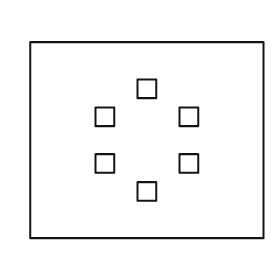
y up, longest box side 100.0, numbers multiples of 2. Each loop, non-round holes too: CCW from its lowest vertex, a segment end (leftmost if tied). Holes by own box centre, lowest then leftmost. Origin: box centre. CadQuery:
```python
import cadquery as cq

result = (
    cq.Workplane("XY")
    .moveTo(-50.0, -42.0)
    .lineTo(50.0, -42.0)
    .lineTo(50.0, 42.0)
    .lineTo(-50.0, 42.0)
    .close()
    .moveTo(-4.0, -26.0)
    .lineTo(4.0, -26.0)
    .lineTo(4.0, -18.0)
    .lineTo(-4.0, -18.0)
    .close()
    .moveTo(-22.0, -14.0)
    .lineTo(-14.0, -14.0)
    .lineTo(-14.0, -6.0)
    .lineTo(-22.0, -6.0)
    .close()
    .moveTo(14.0, -14.0)
    .lineTo(22.0, -14.0)
    .lineTo(22.0, -6.0)
    .lineTo(14.0, -6.0)
    .close()
    .moveTo(-22.0, 6.0)
    .lineTo(-14.0, 6.0)
    .lineTo(-14.0, 14.0)
    .lineTo(-22.0, 14.0)
    .close()
    .moveTo(14.0, 6.0)
    .lineTo(22.0, 6.0)
    .lineTo(22.0, 14.0)
    .lineTo(14.0, 14.0)
    .close()
    .moveTo(-4.0, 18.0)
    .lineTo(4.0, 18.0)
    .lineTo(4.0, 26.0)
    .lineTo(-4.0, 26.0)
    .close()
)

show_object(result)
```